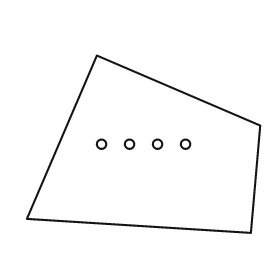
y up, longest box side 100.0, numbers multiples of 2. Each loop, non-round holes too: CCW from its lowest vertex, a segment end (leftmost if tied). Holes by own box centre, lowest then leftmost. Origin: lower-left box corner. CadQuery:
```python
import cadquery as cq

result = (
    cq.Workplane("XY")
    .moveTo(96.0, 0.0)
    .lineTo(100.0, 46.0)
    .lineTo(30.0, 76.0)
    .lineTo(0.0, 6.0)
    .close()
    .moveTo(32.0, 38.0)
    .circle(2.0)
    .moveTo(44.0, 38.0)
    .circle(2.0)
    .moveTo(56.0, 38.0)
    .circle(2.0)
    .moveTo(68.0, 38.0)
    .circle(2.0)
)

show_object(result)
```